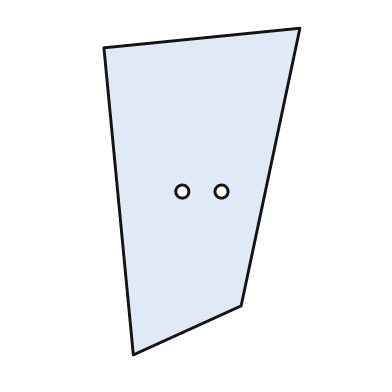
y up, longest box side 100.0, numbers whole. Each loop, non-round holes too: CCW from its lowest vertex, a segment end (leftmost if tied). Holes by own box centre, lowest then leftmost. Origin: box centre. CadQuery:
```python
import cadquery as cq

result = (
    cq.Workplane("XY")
    .moveTo(-21.0, -50.0)
    .lineTo(12.0, -35.0)
    .lineTo(30.0, 50.0)
    .lineTo(-30.0, 44.0)
    .close()
    .moveTo(-6.0, 0.0)
    .circle(2.0)
    .moveTo(6.0, 0.0)
    .circle(2.0)
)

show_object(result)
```